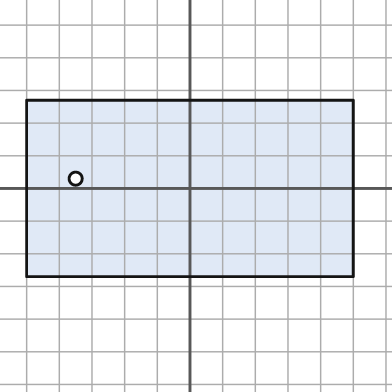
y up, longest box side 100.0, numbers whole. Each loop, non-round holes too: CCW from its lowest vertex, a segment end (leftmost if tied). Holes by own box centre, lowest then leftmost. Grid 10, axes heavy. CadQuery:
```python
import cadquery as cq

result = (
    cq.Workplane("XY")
    .moveTo(-50.0, -27.0)
    .lineTo(50.0, -27.0)
    .lineTo(50.0, 27.0)
    .lineTo(-50.0, 27.0)
    .close()
    .moveTo(-35.0, 3.0)
    .circle(2.0)
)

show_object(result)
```